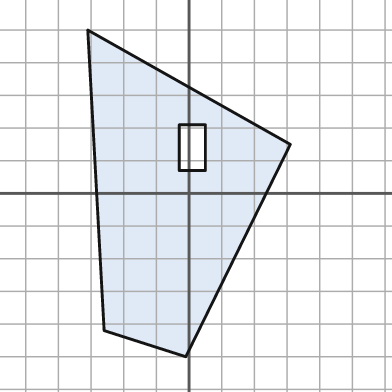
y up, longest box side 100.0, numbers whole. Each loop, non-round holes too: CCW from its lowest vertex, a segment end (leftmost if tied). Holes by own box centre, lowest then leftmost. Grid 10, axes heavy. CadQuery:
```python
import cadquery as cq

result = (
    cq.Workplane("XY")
    .moveTo(-1.0, -50.0)
    .lineTo(31.0, 15.0)
    .lineTo(-31.0, 50.0)
    .lineTo(-26.0, -42.0)
    .close()
    .moveTo(-3.0, 7.0)
    .lineTo(5.0, 7.0)
    .lineTo(5.0, 21.0)
    .lineTo(-3.0, 21.0)
    .close()
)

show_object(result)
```